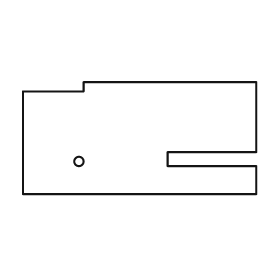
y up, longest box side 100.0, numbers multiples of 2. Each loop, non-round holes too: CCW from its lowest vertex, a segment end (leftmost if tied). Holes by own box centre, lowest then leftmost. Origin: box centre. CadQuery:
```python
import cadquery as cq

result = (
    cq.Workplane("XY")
    .moveTo(-50.0, -24.0)
    .lineTo(50.0, -24.0)
    .lineTo(50.0, -12.0)
    .lineTo(12.0, -12.0)
    .lineTo(12.0, -6.0)
    .lineTo(50.0, -6.0)
    .lineTo(50.0, 24.0)
    .lineTo(-24.0, 24.0)
    .lineTo(-24.0, 20.0)
    .lineTo(-50.0, 20.0)
    .close()
    .moveTo(-26.0, -10.0)
    .circle(2.0)
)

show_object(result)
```